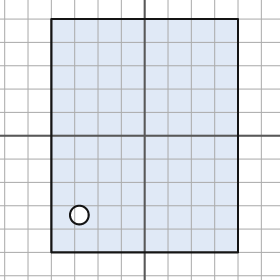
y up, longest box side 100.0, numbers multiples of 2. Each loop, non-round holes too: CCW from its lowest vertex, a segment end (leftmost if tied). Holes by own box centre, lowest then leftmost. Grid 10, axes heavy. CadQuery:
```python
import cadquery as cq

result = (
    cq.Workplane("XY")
    .moveTo(-40.0, -50.0)
    .lineTo(40.0, -50.0)
    .lineTo(40.0, 50.0)
    .lineTo(-40.0, 50.0)
    .close()
    .moveTo(-28.0, -34.0)
    .circle(4.0)
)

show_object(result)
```